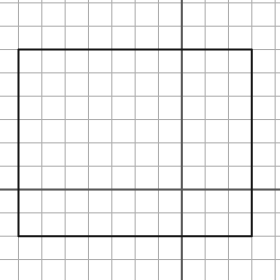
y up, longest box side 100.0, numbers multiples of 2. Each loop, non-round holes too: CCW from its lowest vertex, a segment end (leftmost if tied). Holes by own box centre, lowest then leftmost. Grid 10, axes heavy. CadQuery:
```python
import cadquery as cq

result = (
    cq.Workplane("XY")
    .moveTo(-70.0, -20.0)
    .lineTo(30.0, -20.0)
    .lineTo(30.0, 60.0)
    .lineTo(-70.0, 60.0)
    .close()
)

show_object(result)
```